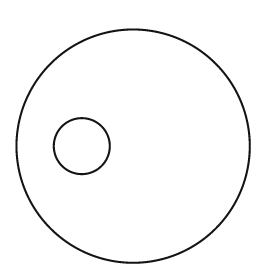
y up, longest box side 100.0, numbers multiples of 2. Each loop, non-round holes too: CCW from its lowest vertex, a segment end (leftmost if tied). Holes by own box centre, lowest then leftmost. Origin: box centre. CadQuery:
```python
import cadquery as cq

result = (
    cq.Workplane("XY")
    .moveTo(0.0, 0.0)
    .circle(50.0)
    .moveTo(-22.0, 0.0)
    .circle(12.0)
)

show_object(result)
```